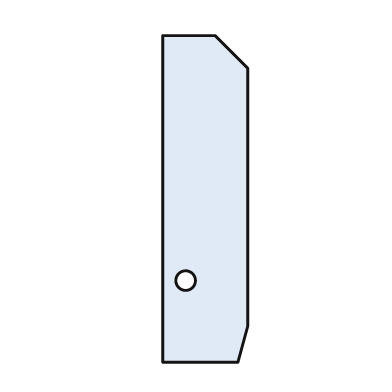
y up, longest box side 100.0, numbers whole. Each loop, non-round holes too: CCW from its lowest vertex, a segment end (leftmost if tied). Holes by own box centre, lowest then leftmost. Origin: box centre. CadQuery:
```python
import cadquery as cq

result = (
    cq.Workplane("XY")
    .moveTo(-13.0, -50.0)
    .lineTo(10.0, -50.0)
    .lineTo(13.0, -39.0)
    .lineTo(13.0, 40.0)
    .lineTo(3.0, 50.0)
    .lineTo(-13.0, 50.0)
    .close()
    .moveTo(-6.0, -25.0)
    .circle(3.0)
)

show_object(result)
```